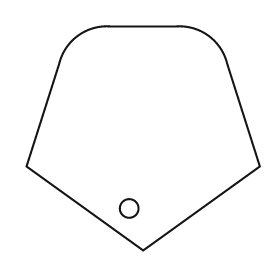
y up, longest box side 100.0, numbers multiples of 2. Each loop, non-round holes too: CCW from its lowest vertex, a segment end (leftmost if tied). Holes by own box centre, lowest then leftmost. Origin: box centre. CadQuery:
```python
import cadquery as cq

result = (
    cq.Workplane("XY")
    .moveTo(0.0, -48.0)
    .lineTo(50.0, -12.0)
    .lineTo(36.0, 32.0)
    .threePointArc((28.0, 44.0), (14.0, 48.0))
    .lineTo(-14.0, 48.0)
    .threePointArc((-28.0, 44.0), (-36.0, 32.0))
    .lineTo(-50.0, -12.0)
    .close()
    .moveTo(-6.0, -30.0)
    .circle(4.0)
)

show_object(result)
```